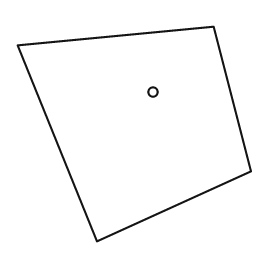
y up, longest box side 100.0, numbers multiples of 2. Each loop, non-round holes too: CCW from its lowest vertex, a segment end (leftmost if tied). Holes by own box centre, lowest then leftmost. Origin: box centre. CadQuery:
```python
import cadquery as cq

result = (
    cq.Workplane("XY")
    .moveTo(-16.0, -46.0)
    .lineTo(50.0, -16.0)
    .lineTo(34.0, 46.0)
    .lineTo(-50.0, 38.0)
    .close()
    .moveTo(8.0, 18.0)
    .circle(2.0)
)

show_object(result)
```